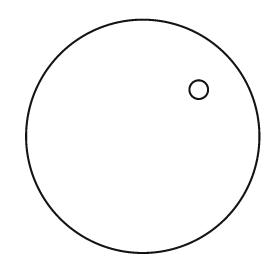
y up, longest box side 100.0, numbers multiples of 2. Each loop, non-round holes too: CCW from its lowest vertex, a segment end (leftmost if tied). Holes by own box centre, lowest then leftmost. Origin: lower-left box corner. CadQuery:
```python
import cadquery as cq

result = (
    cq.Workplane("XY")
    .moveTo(50.0, 50.0)
    .circle(50.0)
    .moveTo(74.0, 70.0)
    .circle(4.0)
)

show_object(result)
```